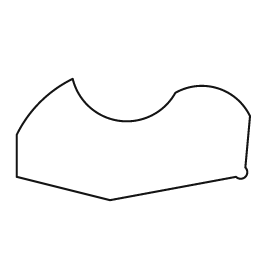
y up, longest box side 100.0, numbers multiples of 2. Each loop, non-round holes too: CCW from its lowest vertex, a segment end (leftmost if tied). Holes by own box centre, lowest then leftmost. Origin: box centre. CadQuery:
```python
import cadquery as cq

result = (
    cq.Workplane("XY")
    .moveTo(-10.0, -26.0)
    .lineTo(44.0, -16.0)
    .threePointArc((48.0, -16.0), (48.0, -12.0))
    .lineTo(50.0, 10.0)
    .threePointArc((36.0, 22.0), (18.0, 20.0))
    .threePointArc((-6.0, 8.0), (-26.0, 26.0))
    .threePointArc((-40.0, 16.0), (-50.0, 2.0))
    .lineTo(-50.0, -16.0)
    .close()
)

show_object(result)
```